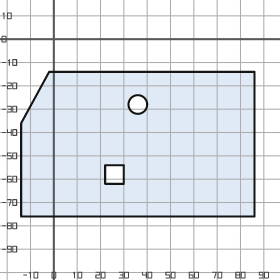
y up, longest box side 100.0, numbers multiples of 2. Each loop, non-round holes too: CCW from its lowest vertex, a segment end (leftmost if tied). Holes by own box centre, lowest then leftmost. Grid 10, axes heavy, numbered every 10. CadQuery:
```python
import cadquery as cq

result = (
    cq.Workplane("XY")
    .moveTo(-14.0, -76.0)
    .lineTo(86.0, -76.0)
    .lineTo(86.0, -14.0)
    .lineTo(-2.0, -14.0)
    .lineTo(-14.0, -36.0)
    .close()
    .moveTo(22.0, -62.0)
    .lineTo(30.0, -62.0)
    .lineTo(30.0, -54.0)
    .lineTo(22.0, -54.0)
    .close()
    .moveTo(36.0, -28.0)
    .circle(4.0)
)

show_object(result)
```